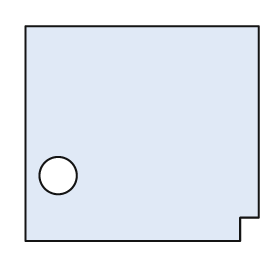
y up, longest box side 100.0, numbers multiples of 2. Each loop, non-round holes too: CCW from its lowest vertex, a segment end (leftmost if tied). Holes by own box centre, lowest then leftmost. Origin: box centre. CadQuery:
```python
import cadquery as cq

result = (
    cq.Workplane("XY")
    .moveTo(-50.0, -46.0)
    .lineTo(42.0, -46.0)
    .lineTo(42.0, -36.0)
    .lineTo(50.0, -36.0)
    .lineTo(50.0, 46.0)
    .lineTo(-50.0, 46.0)
    .close()
    .moveTo(-36.0, -18.0)
    .circle(8.0)
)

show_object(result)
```